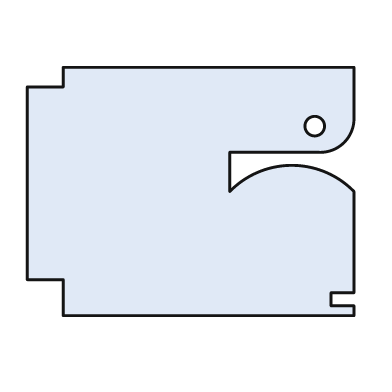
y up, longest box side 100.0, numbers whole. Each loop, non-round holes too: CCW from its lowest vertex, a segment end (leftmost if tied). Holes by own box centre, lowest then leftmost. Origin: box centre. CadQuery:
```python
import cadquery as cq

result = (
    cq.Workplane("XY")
    .moveTo(-39.0, -38.0)
    .lineTo(50.0, -38.0)
    .lineTo(50.0, -35.0)
    .lineTo(43.0, -35.0)
    .lineTo(43.0, -31.0)
    .lineTo(50.0, -31.0)
    .lineTo(50.0, 0.0)
    .threePointArc((31.0, 8.0), (12.0, 0.0))
    .lineTo(12.0, 12.0)
    .lineTo(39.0, 12.0)
    .threePointArc((47.0, 15.0), (50.0, 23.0))
    .lineTo(50.0, 38.0)
    .lineTo(-39.0, 38.0)
    .lineTo(-39.0, 32.0)
    .lineTo(-50.0, 32.0)
    .lineTo(-50.0, -27.0)
    .lineTo(-39.0, -27.0)
    .close()
    .moveTo(38.0, 20.0)
    .circle(3.0)
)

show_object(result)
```